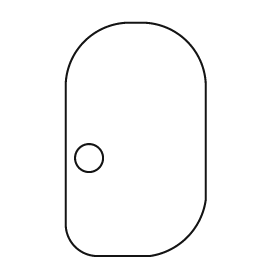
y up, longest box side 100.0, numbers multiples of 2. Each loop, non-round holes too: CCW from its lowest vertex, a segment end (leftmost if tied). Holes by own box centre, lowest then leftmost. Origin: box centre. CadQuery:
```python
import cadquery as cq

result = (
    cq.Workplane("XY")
    .moveTo(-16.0, -50.0)
    .lineTo(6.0, -50.0)
    .threePointArc((22.0, -42.0), (30.0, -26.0))
    .lineTo(30.0, 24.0)
    .threePointArc((22.0, 42.0), (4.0, 50.0))
    .lineTo(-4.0, 50.0)
    .threePointArc((-22.0, 42.0), (-30.0, 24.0))
    .lineTo(-30.0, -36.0)
    .threePointArc((-26.0, -46.0), (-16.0, -50.0))
    .close()
    .moveTo(-20.0, -8.0)
    .circle(6.0)
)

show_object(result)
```